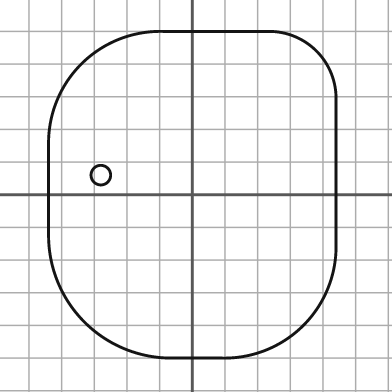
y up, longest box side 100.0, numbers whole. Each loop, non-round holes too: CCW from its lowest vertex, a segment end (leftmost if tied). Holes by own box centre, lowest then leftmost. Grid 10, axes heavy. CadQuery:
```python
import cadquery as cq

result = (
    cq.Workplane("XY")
    .moveTo(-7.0, -50.0)
    .lineTo(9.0, -50.0)
    .threePointArc((34.0, -40.0), (44.0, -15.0))
    .lineTo(44.0, 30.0)
    .threePointArc((38.0, 44.0), (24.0, 50.0))
    .lineTo(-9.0, 50.0)
    .threePointArc((-34.0, 40.0), (-44.0, 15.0))
    .lineTo(-44.0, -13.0)
    .threePointArc((-33.0, -39.0), (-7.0, -50.0))
    .close()
    .moveTo(-28.0, 6.0)
    .circle(3.0)
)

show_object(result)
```